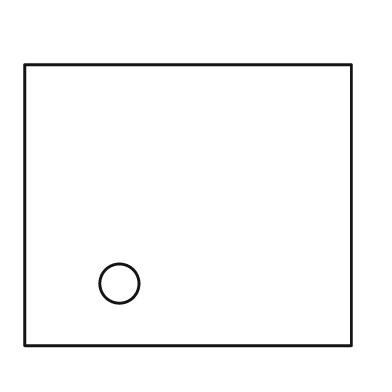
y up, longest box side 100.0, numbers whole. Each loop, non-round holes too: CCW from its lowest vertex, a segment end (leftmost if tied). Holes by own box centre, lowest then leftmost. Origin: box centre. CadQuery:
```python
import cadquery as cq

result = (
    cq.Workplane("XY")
    .moveTo(-50.0, -43.0)
    .lineTo(50.0, -43.0)
    .lineTo(50.0, 43.0)
    .lineTo(-50.0, 43.0)
    .close()
    .moveTo(-21.0, -24.0)
    .circle(6.0)
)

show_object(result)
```